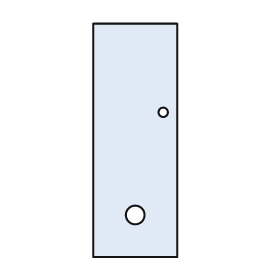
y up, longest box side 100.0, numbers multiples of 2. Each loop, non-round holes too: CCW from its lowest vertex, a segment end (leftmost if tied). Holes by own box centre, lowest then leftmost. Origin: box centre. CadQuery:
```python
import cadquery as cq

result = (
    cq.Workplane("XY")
    .moveTo(-18.0, -50.0)
    .lineTo(18.0, -50.0)
    .lineTo(18.0, 50.0)
    .lineTo(-18.0, 50.0)
    .close()
    .moveTo(0.0, -32.0)
    .circle(4.0)
    .moveTo(12.0, 12.0)
    .circle(2.0)
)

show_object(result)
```